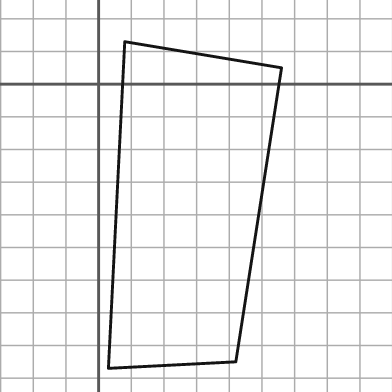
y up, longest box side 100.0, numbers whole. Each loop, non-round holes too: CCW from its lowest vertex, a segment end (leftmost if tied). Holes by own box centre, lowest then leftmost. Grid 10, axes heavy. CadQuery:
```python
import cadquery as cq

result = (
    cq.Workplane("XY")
    .moveTo(3.0, -87.0)
    .lineTo(42.0, -85.0)
    .lineTo(56.0, 5.0)
    .lineTo(8.0, 13.0)
    .close()
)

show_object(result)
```